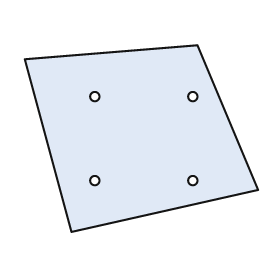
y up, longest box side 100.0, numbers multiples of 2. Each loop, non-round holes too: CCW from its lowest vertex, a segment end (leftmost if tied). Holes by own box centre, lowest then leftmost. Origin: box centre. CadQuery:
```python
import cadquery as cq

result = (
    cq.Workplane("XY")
    .moveTo(-30.0, -40.0)
    .lineTo(50.0, -22.0)
    .lineTo(24.0, 40.0)
    .lineTo(-50.0, 34.0)
    .close()
    .moveTo(-20.0, -18.0)
    .circle(2.0)
    .moveTo(22.0, -18.0)
    .circle(2.0)
    .moveTo(-20.0, 18.0)
    .circle(2.0)
    .moveTo(22.0, 18.0)
    .circle(2.0)
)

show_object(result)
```